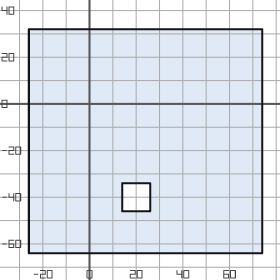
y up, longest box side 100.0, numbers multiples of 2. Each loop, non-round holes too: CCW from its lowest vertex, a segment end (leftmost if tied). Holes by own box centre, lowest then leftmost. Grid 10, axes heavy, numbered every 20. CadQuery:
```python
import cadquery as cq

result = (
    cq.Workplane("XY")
    .moveTo(-26.0, -64.0)
    .lineTo(74.0, -64.0)
    .lineTo(74.0, 32.0)
    .lineTo(-26.0, 32.0)
    .close()
    .moveTo(14.0, -46.0)
    .lineTo(26.0, -46.0)
    .lineTo(26.0, -34.0)
    .lineTo(14.0, -34.0)
    .close()
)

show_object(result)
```